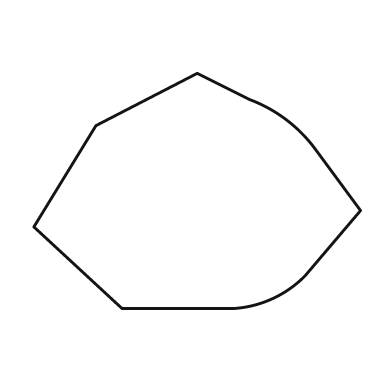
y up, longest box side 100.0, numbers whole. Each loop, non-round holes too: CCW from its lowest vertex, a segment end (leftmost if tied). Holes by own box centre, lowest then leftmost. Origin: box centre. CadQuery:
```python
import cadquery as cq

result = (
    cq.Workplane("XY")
    .moveTo(-23.0, -36.0)
    .lineTo(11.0, -36.0)
    .threePointArc((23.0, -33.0), (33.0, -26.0))
    .lineTo(50.0, -6.0)
    .lineTo(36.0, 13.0)
    .threePointArc((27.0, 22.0), (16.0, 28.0))
    .lineTo(0.0, 36.0)
    .lineTo(-31.0, 20.0)
    .lineTo(-50.0, -11.0)
    .close()
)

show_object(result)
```